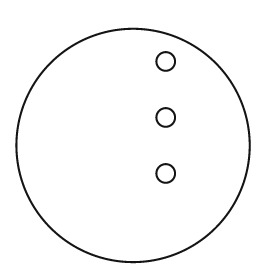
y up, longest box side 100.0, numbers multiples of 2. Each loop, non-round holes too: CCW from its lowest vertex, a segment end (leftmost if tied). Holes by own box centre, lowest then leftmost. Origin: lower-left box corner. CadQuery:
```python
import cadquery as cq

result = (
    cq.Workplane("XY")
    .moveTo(50.0, 50.0)
    .circle(50.0)
    .moveTo(64.0, 38.0)
    .circle(4.0)
    .moveTo(64.0, 62.0)
    .circle(4.0)
    .moveTo(64.0, 86.0)
    .circle(4.0)
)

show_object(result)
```